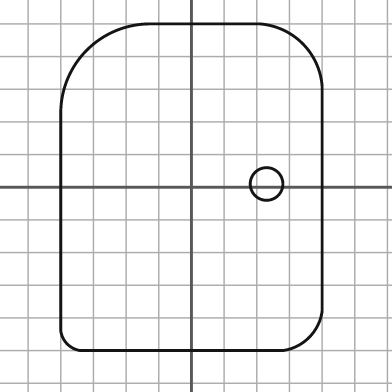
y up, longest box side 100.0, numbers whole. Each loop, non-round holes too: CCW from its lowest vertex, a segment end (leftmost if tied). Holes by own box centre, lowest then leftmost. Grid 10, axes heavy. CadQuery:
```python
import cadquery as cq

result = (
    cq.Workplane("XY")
    .moveTo(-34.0, -50.0)
    .lineTo(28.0, -50.0)
    .threePointArc((36.0, -46.0), (40.0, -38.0))
    .lineTo(40.0, 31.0)
    .threePointArc((34.0, 44.0), (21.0, 50.0))
    .lineTo(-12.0, 50.0)
    .threePointArc((-32.0, 42.0), (-40.0, 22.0))
    .lineTo(-40.0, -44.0)
    .threePointArc((-38.0, -48.0), (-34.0, -50.0))
    .close()
    .moveTo(23.0, 1.0)
    .circle(5.0)
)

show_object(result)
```